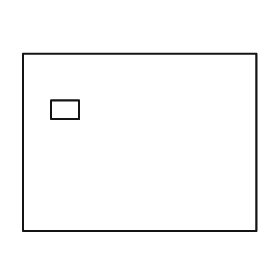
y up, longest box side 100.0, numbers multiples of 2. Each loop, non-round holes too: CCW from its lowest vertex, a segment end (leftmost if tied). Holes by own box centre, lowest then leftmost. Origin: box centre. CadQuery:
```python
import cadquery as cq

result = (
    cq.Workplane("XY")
    .moveTo(-50.0, -38.0)
    .lineTo(50.0, -38.0)
    .lineTo(50.0, 38.0)
    .lineTo(-50.0, 38.0)
    .close()
    .moveTo(-38.0, 10.0)
    .lineTo(-26.0, 10.0)
    .lineTo(-26.0, 18.0)
    .lineTo(-38.0, 18.0)
    .close()
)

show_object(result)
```